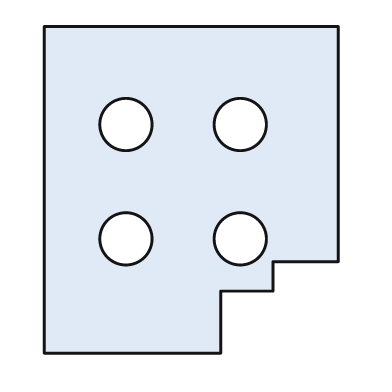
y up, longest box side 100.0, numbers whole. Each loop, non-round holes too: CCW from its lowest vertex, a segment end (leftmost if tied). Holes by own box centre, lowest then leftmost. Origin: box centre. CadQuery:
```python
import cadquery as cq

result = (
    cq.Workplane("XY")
    .moveTo(-45.0, -50.0)
    .lineTo(9.0, -50.0)
    .lineTo(9.0, -31.0)
    .lineTo(25.0, -31.0)
    .lineTo(25.0, -22.0)
    .lineTo(45.0, -22.0)
    .lineTo(45.0, 50.0)
    .lineTo(-45.0, 50.0)
    .close()
    .moveTo(-20.0, -15.0)
    .circle(8.0)
    .moveTo(15.0, -15.0)
    .circle(8.0)
    .moveTo(-20.0, 20.0)
    .circle(8.0)
    .moveTo(15.0, 20.0)
    .circle(8.0)
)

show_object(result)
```